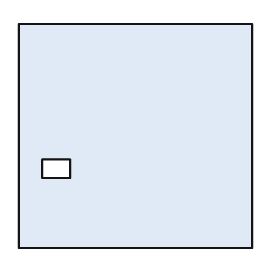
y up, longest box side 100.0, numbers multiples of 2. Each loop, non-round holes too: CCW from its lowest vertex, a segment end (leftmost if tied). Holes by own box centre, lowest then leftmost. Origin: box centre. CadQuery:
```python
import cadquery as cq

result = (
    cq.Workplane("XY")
    .moveTo(-50.0, -48.0)
    .lineTo(50.0, -48.0)
    .lineTo(50.0, 48.0)
    .lineTo(-50.0, 48.0)
    .close()
    .moveTo(-40.0, -18.0)
    .lineTo(-28.0, -18.0)
    .lineTo(-28.0, -10.0)
    .lineTo(-40.0, -10.0)
    .close()
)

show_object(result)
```